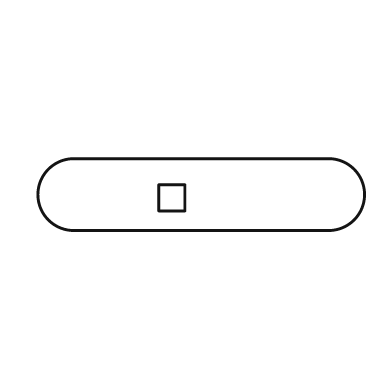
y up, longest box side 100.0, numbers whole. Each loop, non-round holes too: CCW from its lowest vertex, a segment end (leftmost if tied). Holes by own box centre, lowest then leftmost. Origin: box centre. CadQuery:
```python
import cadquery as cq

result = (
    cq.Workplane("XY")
    .moveTo(-39.0, -11.0)
    .lineTo(39.0, -11.0)
    .threePointArc((50.0, 0.0), (39.0, 11.0))
    .lineTo(-39.0, 11.0)
    .threePointArc((-50.0, 0.0), (-39.0, -11.0))
    .close()
    .moveTo(-13.0, -5.0)
    .lineTo(-5.0, -5.0)
    .lineTo(-5.0, 3.0)
    .lineTo(-13.0, 3.0)
    .close()
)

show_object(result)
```